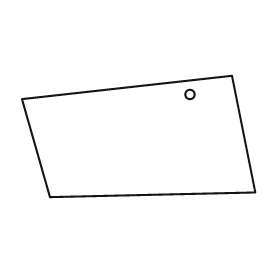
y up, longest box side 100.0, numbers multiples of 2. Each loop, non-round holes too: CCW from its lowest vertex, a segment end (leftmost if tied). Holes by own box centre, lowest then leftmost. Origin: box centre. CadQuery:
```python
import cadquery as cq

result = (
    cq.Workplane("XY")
    .moveTo(-38.0, -26.0)
    .lineTo(50.0, -24.0)
    .lineTo(40.0, 26.0)
    .lineTo(-50.0, 16.0)
    .close()
    .moveTo(22.0, 18.0)
    .circle(2.0)
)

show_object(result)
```